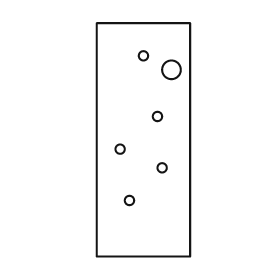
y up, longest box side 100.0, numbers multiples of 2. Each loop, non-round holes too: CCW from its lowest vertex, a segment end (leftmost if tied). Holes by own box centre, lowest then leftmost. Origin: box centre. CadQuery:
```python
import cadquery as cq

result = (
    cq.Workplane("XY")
    .moveTo(-20.0, -50.0)
    .lineTo(20.0, -50.0)
    .lineTo(20.0, 50.0)
    .lineTo(-20.0, 50.0)
    .close()
    .moveTo(-6.0, -26.0)
    .circle(2.0)
    .moveTo(8.0, -12.0)
    .circle(2.0)
    .moveTo(-10.0, -4.0)
    .circle(2.0)
    .moveTo(6.0, 10.0)
    .circle(2.0)
    .moveTo(12.0, 30.0)
    .circle(4.0)
    .moveTo(0.0, 36.0)
    .circle(2.0)
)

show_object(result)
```